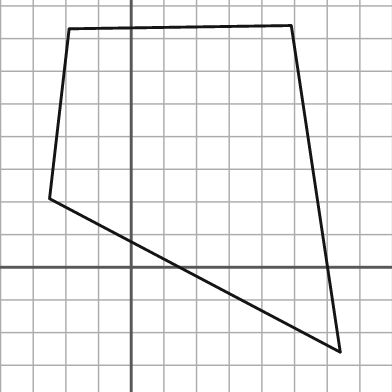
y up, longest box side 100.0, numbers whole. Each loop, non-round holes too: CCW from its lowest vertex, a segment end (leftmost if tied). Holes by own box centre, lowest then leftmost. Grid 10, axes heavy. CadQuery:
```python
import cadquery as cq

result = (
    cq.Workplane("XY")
    .moveTo(64.0, -26.0)
    .lineTo(49.0, 74.0)
    .lineTo(-19.0, 73.0)
    .lineTo(-25.0, 21.0)
    .close()
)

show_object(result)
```